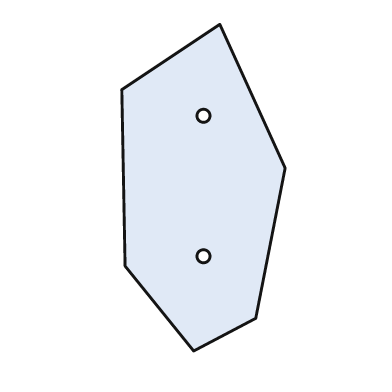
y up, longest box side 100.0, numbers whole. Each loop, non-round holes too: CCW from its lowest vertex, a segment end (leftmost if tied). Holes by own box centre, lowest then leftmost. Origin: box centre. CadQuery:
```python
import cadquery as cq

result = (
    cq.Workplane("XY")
    .moveTo(-3.0, -50.0)
    .lineTo(16.0, -40.0)
    .lineTo(25.0, 6.0)
    .lineTo(5.0, 50.0)
    .lineTo(-25.0, 30.0)
    .lineTo(-24.0, -24.0)
    .close()
    .moveTo(0.0, -21.0)
    .circle(2.0)
    .moveTo(0.0, 22.0)
    .circle(2.0)
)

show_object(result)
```